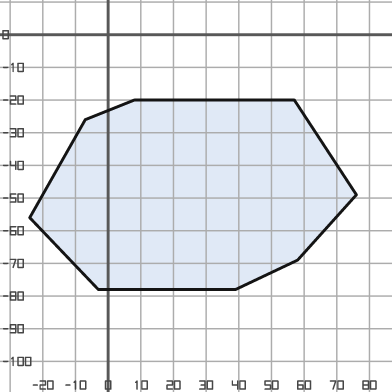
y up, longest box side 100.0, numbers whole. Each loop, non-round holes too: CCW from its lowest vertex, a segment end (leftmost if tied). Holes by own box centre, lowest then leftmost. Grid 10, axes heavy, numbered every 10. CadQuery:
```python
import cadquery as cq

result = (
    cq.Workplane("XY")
    .moveTo(-3.0, -78.0)
    .lineTo(39.0, -78.0)
    .lineTo(58.0, -69.0)
    .lineTo(76.0, -49.0)
    .lineTo(57.0, -20.0)
    .lineTo(8.0, -20.0)
    .lineTo(-7.0, -26.0)
    .lineTo(-24.0, -56.0)
    .close()
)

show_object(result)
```